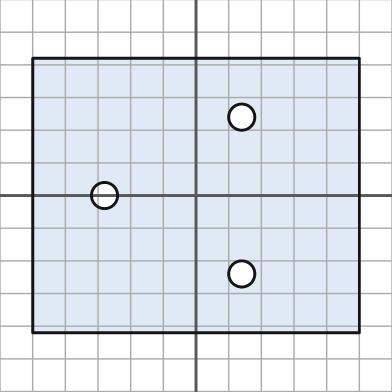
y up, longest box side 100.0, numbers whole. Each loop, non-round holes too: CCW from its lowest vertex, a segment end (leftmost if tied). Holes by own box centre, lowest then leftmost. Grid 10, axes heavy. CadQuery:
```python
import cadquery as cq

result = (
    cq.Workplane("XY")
    .moveTo(-50.0, -42.0)
    .lineTo(50.0, -42.0)
    .lineTo(50.0, 42.0)
    .lineTo(-50.0, 42.0)
    .close()
    .moveTo(14.0, -24.0)
    .circle(4.0)
    .moveTo(-28.0, 0.0)
    .circle(4.0)
    .moveTo(14.0, 24.0)
    .circle(4.0)
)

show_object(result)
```